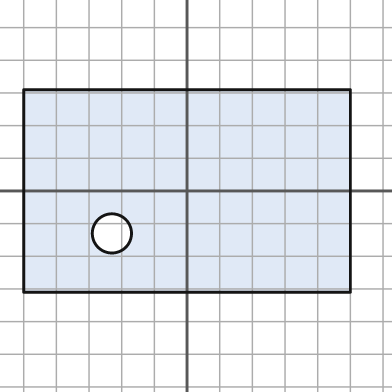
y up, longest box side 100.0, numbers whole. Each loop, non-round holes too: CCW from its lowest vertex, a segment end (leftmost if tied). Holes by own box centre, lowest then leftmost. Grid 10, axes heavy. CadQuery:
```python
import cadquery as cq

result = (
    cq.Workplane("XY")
    .moveTo(-50.0, -31.0)
    .lineTo(50.0, -31.0)
    .lineTo(50.0, 31.0)
    .lineTo(-50.0, 31.0)
    .close()
    .moveTo(-23.0, -13.0)
    .circle(6.0)
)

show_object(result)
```